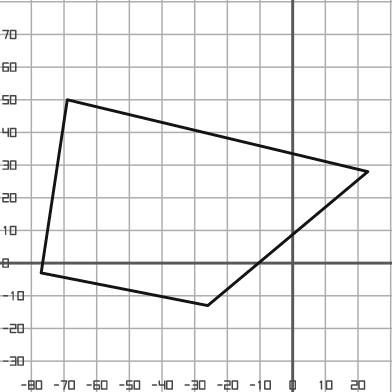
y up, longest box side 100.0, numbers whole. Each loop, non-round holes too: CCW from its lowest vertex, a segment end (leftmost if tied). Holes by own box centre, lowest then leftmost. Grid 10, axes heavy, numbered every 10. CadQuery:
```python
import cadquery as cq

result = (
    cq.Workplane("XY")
    .moveTo(-26.0, -13.0)
    .lineTo(23.0, 28.0)
    .lineTo(-69.0, 50.0)
    .lineTo(-77.0, -3.0)
    .close()
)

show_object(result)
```